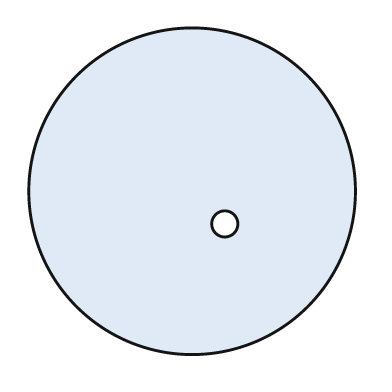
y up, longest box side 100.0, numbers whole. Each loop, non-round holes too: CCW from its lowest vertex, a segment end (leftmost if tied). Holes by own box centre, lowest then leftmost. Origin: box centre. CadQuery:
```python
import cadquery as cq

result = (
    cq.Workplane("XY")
    .moveTo(0.0, 0.0)
    .circle(50.0)
    .moveTo(10.0, -10.0)
    .circle(4.0)
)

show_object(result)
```